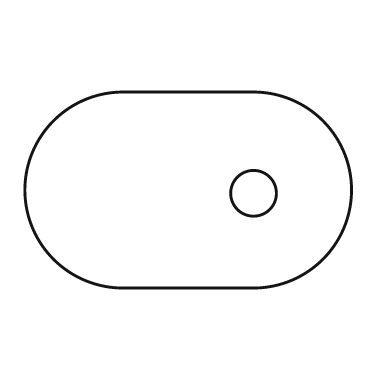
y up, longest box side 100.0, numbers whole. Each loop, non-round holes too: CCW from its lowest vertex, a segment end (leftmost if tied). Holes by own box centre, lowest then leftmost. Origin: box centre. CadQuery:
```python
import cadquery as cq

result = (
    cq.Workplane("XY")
    .moveTo(-20.0, -30.0)
    .lineTo(20.0, -30.0)
    .threePointArc((50.0, 0.0), (20.0, 30.0))
    .lineTo(-20.0, 30.0)
    .threePointArc((-50.0, 0.0), (-20.0, -30.0))
    .close()
    .moveTo(20.0, -1.0)
    .circle(7.0)
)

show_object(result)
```